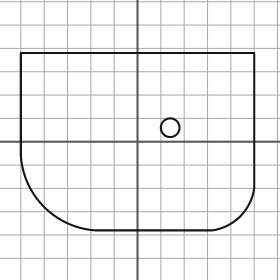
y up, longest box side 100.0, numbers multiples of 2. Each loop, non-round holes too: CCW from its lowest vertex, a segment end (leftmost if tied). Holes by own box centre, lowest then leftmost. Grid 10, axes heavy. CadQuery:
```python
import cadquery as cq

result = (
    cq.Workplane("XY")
    .moveTo(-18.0, -38.0)
    .lineTo(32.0, -38.0)
    .threePointArc((44.0, -32.0), (50.0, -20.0))
    .lineTo(50.0, 38.0)
    .lineTo(-50.0, 38.0)
    .lineTo(-50.0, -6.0)
    .threePointArc((-40.0, -28.0), (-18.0, -38.0))
    .close()
    .moveTo(14.0, 6.0)
    .circle(4.0)
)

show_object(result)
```